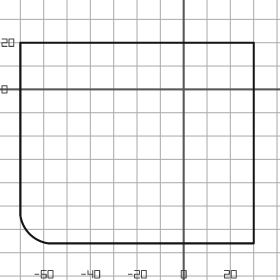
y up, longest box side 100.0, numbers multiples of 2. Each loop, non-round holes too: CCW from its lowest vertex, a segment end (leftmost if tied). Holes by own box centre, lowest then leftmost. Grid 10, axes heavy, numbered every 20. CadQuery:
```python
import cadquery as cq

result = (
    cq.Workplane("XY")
    .moveTo(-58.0, -66.0)
    .lineTo(30.0, -66.0)
    .lineTo(30.0, 20.0)
    .lineTo(-70.0, 20.0)
    .lineTo(-70.0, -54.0)
    .threePointArc((-66.0, -62.0), (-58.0, -66.0))
    .close()
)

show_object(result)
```